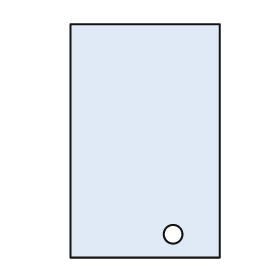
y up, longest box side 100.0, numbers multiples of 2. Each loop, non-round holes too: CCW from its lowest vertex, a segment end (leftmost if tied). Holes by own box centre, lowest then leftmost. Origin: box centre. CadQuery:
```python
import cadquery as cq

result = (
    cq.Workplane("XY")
    .moveTo(-32.0, -50.0)
    .lineTo(32.0, -50.0)
    .lineTo(32.0, 50.0)
    .lineTo(-32.0, 50.0)
    .close()
    .moveTo(12.0, -40.0)
    .circle(4.0)
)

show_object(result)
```